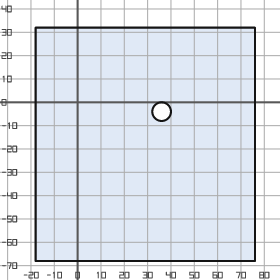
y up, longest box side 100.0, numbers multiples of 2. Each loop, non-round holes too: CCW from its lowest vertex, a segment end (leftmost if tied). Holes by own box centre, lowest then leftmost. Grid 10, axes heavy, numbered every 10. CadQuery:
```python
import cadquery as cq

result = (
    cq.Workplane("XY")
    .moveTo(-18.0, -68.0)
    .lineTo(76.0, -68.0)
    .lineTo(76.0, 32.0)
    .lineTo(-18.0, 32.0)
    .close()
    .moveTo(36.0, -4.0)
    .circle(4.0)
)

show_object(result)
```